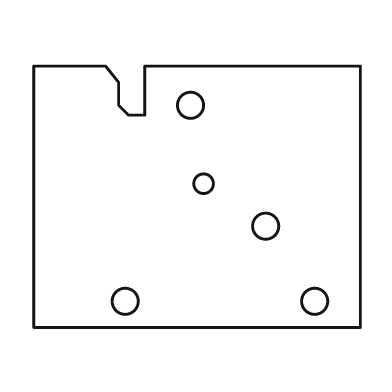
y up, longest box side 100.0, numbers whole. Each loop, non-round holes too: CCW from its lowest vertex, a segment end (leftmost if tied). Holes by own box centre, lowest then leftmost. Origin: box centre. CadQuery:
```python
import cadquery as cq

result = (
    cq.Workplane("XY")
    .moveTo(-50.0, -40.0)
    .lineTo(50.0, -40.0)
    .lineTo(50.0, 40.0)
    .lineTo(-16.0, 40.0)
    .lineTo(-16.0, 25.0)
    .lineTo(-21.0, 25.0)
    .lineTo(-24.0, 28.0)
    .lineTo(-24.0, 35.0)
    .lineTo(-28.0, 40.0)
    .lineTo(-50.0, 40.0)
    .close()
    .moveTo(-22.0, -32.0)
    .circle(4.0)
    .moveTo(36.0, -32.0)
    .circle(4.0)
    .moveTo(21.0, -9.0)
    .circle(4.0)
    .moveTo(2.0, 4.0)
    .circle(3.0)
    .moveTo(-2.0, 28.0)
    .circle(4.0)
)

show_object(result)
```